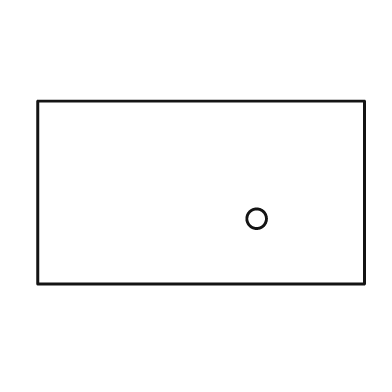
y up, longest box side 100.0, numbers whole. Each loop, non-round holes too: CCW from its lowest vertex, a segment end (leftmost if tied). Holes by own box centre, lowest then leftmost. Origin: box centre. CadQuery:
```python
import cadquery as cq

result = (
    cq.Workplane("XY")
    .moveTo(-50.0, -28.0)
    .lineTo(50.0, -28.0)
    .lineTo(50.0, 28.0)
    .lineTo(-50.0, 28.0)
    .close()
    .moveTo(17.0, -8.0)
    .circle(3.0)
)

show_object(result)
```